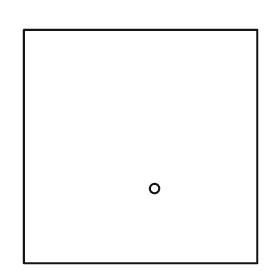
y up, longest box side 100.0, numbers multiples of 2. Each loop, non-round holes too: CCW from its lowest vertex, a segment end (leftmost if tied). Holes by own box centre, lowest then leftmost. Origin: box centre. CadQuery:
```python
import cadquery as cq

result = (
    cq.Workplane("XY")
    .moveTo(-50.0, -50.0)
    .lineTo(50.0, -50.0)
    .lineTo(50.0, 50.0)
    .lineTo(-50.0, 50.0)
    .close()
    .moveTo(6.0, -18.0)
    .circle(2.0)
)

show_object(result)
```